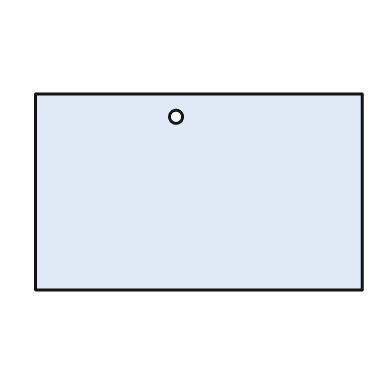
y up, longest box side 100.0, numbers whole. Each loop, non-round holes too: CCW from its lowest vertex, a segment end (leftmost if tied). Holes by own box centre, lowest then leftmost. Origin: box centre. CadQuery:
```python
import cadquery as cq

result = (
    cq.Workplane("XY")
    .moveTo(-50.0, -30.0)
    .lineTo(50.0, -30.0)
    .lineTo(50.0, 30.0)
    .lineTo(-50.0, 30.0)
    .close()
    .moveTo(-7.0, 23.0)
    .circle(2.0)
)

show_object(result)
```